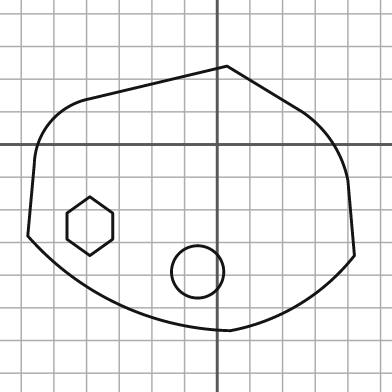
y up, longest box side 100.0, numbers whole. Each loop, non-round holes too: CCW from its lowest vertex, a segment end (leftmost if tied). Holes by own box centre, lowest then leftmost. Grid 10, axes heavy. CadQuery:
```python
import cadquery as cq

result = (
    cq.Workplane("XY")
    .moveTo(4.0, -57.0)
    .threePointArc((25.0, -49.0), (42.0, -34.0))
    .lineTo(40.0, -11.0)
    .threePointArc((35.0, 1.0), (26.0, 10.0))
    .lineTo(3.0, 24.0)
    .lineTo(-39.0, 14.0)
    .threePointArc((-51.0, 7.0), (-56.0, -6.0))
    .lineTo(-58.0, -28.0)
    .threePointArc((-30.0, -49.0), (4.0, -57.0))
    .close()
    .moveTo(-6.0, -39.0)
    .circle(8.0)
    .moveTo(-39.0, -34.0)
    .lineTo(-32.0, -29.0)
    .lineTo(-32.0, -21.0)
    .lineTo(-39.0, -16.0)
    .lineTo(-46.0, -21.0)
    .lineTo(-46.0, -29.0)
    .close()
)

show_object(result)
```